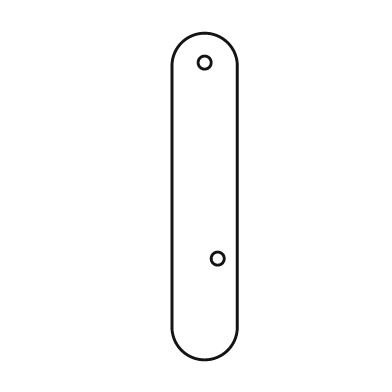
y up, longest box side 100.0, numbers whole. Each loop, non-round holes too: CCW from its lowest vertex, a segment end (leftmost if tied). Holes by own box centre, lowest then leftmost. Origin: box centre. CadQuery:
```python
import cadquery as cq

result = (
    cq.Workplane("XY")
    .moveTo(-10.0, -40.0)
    .threePointArc((0.0, -50.0), (10.0, -40.0))
    .lineTo(10.0, 40.0)
    .threePointArc((0.0, 50.0), (-10.0, 40.0))
    .close()
    .moveTo(4.0, -19.0)
    .circle(2.0)
    .moveTo(0.0, 41.0)
    .circle(2.0)
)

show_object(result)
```